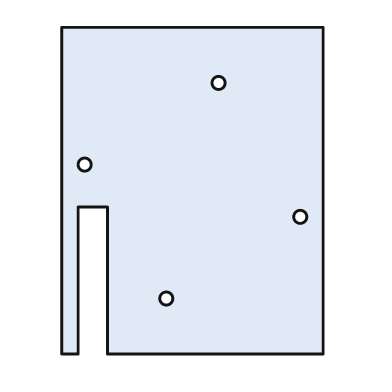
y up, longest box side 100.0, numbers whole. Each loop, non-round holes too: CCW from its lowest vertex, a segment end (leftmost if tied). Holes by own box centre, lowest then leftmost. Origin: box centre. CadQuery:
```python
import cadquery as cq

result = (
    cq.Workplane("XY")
    .moveTo(-40.0, -50.0)
    .lineTo(-35.0, -50.0)
    .lineTo(-35.0, -5.0)
    .lineTo(-26.0, -5.0)
    .lineTo(-26.0, -50.0)
    .lineTo(40.0, -50.0)
    .lineTo(40.0, 50.0)
    .lineTo(-40.0, 50.0)
    .close()
    .moveTo(-8.0, -33.0)
    .circle(2.0)
    .moveTo(33.0, -8.0)
    .circle(2.0)
    .moveTo(-33.0, 8.0)
    .circle(2.0)
    .moveTo(8.0, 33.0)
    .circle(2.0)
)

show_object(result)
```